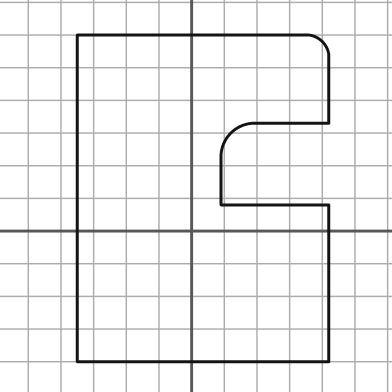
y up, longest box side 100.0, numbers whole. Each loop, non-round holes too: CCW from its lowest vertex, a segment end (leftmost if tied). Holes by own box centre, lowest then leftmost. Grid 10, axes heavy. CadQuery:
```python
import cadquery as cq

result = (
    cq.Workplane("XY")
    .moveTo(-35.0, -40.0)
    .lineTo(42.0, -40.0)
    .lineTo(42.0, 8.0)
    .lineTo(9.0, 8.0)
    .lineTo(9.0, 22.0)
    .threePointArc((12.0, 30.0), (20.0, 33.0))
    .lineTo(42.0, 33.0)
    .lineTo(42.0, 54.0)
    .threePointArc((40.0, 58.0), (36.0, 60.0))
    .lineTo(-35.0, 60.0)
    .close()
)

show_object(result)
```